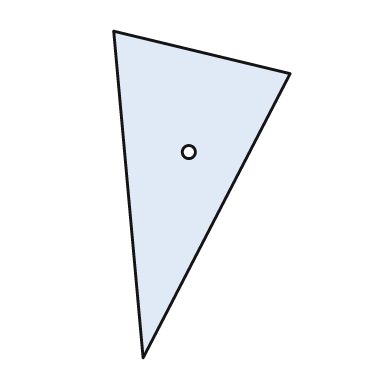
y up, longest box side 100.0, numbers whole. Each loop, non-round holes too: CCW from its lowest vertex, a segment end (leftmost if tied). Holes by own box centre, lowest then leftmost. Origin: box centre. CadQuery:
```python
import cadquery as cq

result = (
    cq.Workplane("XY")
    .moveTo(-18.0, -50.0)
    .lineTo(27.0, 37.0)
    .lineTo(-27.0, 50.0)
    .close()
    .moveTo(-4.0, 13.0)
    .circle(2.0)
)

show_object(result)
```